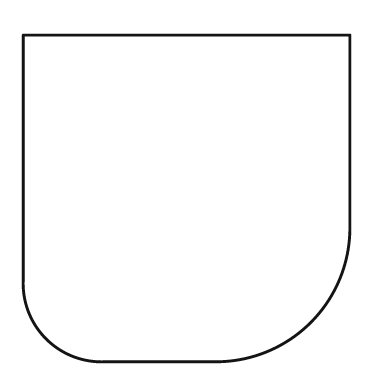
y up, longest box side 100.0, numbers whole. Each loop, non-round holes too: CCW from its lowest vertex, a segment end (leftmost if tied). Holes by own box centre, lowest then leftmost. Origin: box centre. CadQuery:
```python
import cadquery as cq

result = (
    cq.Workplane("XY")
    .moveTo(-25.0, -50.0)
    .lineTo(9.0, -50.0)
    .threePointArc((38.0, -38.0), (50.0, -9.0))
    .lineTo(50.0, 50.0)
    .lineTo(-50.0, 50.0)
    .lineTo(-50.0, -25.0)
    .threePointArc((-43.0, -43.0), (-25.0, -50.0))
    .close()
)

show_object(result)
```